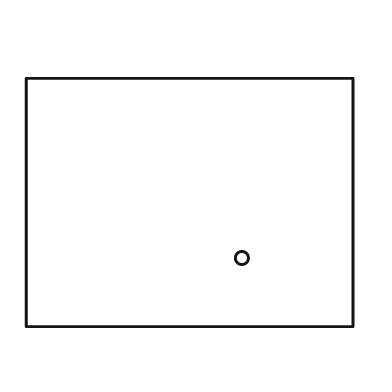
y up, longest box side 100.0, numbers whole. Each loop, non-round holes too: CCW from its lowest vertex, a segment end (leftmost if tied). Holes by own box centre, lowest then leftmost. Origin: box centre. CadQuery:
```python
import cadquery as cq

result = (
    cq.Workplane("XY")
    .moveTo(-50.0, -38.0)
    .lineTo(50.0, -38.0)
    .lineTo(50.0, 38.0)
    .lineTo(-50.0, 38.0)
    .close()
    .moveTo(16.0, -17.0)
    .circle(2.0)
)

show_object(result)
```